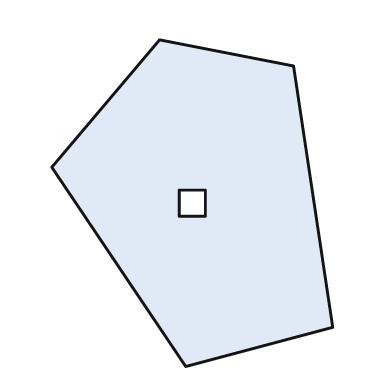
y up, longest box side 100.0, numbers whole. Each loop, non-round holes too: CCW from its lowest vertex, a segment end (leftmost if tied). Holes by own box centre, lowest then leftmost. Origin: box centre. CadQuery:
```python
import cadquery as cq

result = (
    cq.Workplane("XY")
    .moveTo(-2.0, -50.0)
    .lineTo(43.0, -38.0)
    .lineTo(31.0, 42.0)
    .lineTo(-10.0, 50.0)
    .lineTo(-43.0, 11.0)
    .close()
    .moveTo(-4.0, -4.0)
    .lineTo(4.0, -4.0)
    .lineTo(4.0, 4.0)
    .lineTo(-4.0, 4.0)
    .close()
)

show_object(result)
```